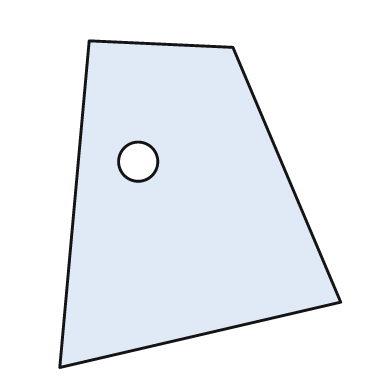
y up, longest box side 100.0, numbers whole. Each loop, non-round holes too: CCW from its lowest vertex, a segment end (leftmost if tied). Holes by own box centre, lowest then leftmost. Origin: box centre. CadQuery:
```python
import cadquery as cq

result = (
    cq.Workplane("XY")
    .moveTo(-43.0, -50.0)
    .lineTo(43.0, -30.0)
    .lineTo(10.0, 48.0)
    .lineTo(-34.0, 50.0)
    .close()
    .moveTo(-19.0, 13.0)
    .circle(6.0)
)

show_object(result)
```